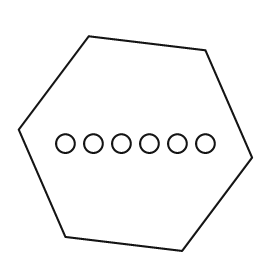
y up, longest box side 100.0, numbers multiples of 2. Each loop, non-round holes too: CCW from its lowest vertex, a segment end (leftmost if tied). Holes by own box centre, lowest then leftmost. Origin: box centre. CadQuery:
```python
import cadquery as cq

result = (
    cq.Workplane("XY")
    .moveTo(20.0, -46.0)
    .lineTo(50.0, -6.0)
    .lineTo(30.0, 40.0)
    .lineTo(-20.0, 46.0)
    .lineTo(-50.0, 6.0)
    .lineTo(-30.0, -40.0)
    .close()
    .moveTo(-30.0, 0.0)
    .circle(4.0)
    .moveTo(-18.0, 0.0)
    .circle(4.0)
    .moveTo(-6.0, 0.0)
    .circle(4.0)
    .moveTo(6.0, 0.0)
    .circle(4.0)
    .moveTo(18.0, 0.0)
    .circle(4.0)
    .moveTo(30.0, 0.0)
    .circle(4.0)
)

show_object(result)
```